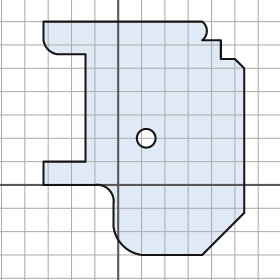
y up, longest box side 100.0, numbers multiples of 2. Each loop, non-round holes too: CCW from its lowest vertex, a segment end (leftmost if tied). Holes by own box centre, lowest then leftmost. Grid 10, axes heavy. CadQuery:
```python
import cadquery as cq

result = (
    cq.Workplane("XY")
    .moveTo(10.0, -30.0)
    .lineTo(36.0, -30.0)
    .lineTo(54.0, -12.0)
    .lineTo(54.0, 50.0)
    .lineTo(50.0, 54.0)
    .lineTo(44.0, 54.0)
    .lineTo(44.0, 62.0)
    .lineTo(36.0, 62.0)
    .threePointArc((38.0, 66.0), (36.0, 70.0))
    .lineTo(-32.0, 70.0)
    .lineTo(-32.0, 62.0)
    .threePointArc((-30.0, 58.0), (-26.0, 56.0))
    .lineTo(-14.0, 56.0)
    .lineTo(-14.0, 10.0)
    .lineTo(-32.0, 10.0)
    .lineTo(-32.0, 0.0)
    .lineTo(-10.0, 0.0)
    .threePointArc((-4.0, -2.0), (-2.0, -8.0))
    .lineTo(-2.0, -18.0)
    .threePointArc((2.0, -26.0), (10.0, -30.0))
    .close()
    .moveTo(12.0, 20.0)
    .circle(4.0)
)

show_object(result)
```